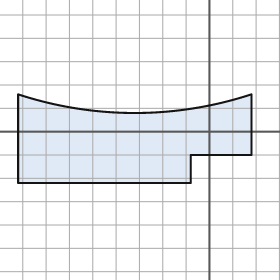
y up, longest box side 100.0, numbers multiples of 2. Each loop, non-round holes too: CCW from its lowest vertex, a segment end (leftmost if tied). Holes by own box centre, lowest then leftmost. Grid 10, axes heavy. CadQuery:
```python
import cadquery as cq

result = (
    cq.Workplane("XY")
    .moveTo(-82.0, -22.0)
    .lineTo(-8.0, -22.0)
    .lineTo(-8.0, -10.0)
    .lineTo(18.0, -10.0)
    .lineTo(18.0, 16.0)
    .threePointArc((-32.0, 8.0), (-82.0, 16.0))
    .close()
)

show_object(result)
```